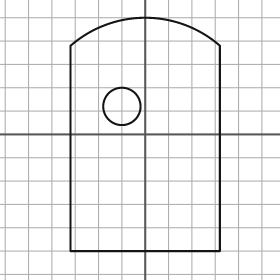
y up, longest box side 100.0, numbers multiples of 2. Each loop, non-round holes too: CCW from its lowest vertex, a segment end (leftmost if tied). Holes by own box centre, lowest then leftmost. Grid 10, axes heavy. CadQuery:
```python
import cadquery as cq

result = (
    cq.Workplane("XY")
    .moveTo(-32.0, -50.0)
    .lineTo(32.0, -50.0)
    .lineTo(32.0, 38.0)
    .threePointArc((0.0, 50.0), (-32.0, 38.0))
    .close()
    .moveTo(-10.0, 12.0)
    .circle(8.0)
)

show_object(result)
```